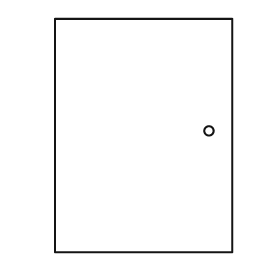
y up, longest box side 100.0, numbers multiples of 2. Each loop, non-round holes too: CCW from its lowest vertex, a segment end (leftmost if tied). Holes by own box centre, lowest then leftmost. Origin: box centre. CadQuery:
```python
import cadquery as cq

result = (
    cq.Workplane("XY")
    .moveTo(-38.0, -50.0)
    .lineTo(38.0, -50.0)
    .lineTo(38.0, 50.0)
    .lineTo(-38.0, 50.0)
    .close()
    .moveTo(28.0, 2.0)
    .circle(2.0)
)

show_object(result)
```